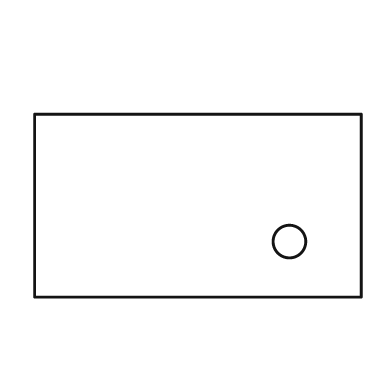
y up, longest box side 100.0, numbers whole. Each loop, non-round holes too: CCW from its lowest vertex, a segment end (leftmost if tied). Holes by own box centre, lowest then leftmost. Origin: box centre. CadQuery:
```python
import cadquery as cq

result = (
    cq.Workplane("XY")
    .moveTo(-50.0, -28.0)
    .lineTo(50.0, -28.0)
    .lineTo(50.0, 28.0)
    .lineTo(-50.0, 28.0)
    .close()
    .moveTo(28.0, -11.0)
    .circle(5.0)
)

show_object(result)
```